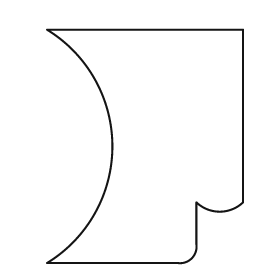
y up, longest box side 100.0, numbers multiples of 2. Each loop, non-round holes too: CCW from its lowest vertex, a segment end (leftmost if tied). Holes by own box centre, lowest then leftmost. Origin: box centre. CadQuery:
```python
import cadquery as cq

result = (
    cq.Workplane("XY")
    .moveTo(-42.0, -50.0)
    .lineTo(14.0, -50.0)
    .threePointArc((20.0, -48.0), (22.0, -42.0))
    .lineTo(22.0, -24.0)
    .threePointArc((32.0, -28.0), (42.0, -24.0))
    .lineTo(42.0, 50.0)
    .lineTo(-42.0, 50.0)
    .threePointArc((-14.0, 0.0), (-42.0, -50.0))
    .close()
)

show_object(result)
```